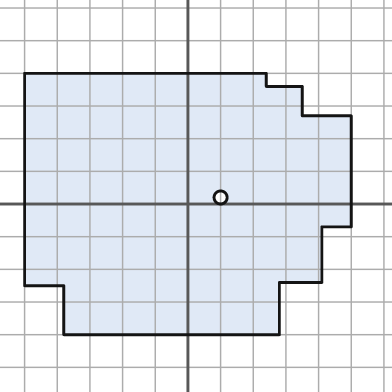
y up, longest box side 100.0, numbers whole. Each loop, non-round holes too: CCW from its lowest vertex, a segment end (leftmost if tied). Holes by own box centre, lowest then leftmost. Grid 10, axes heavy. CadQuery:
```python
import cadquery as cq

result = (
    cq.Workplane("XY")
    .moveTo(-38.0, -40.0)
    .lineTo(28.0, -40.0)
    .lineTo(28.0, -24.0)
    .lineTo(41.0, -24.0)
    .lineTo(41.0, -7.0)
    .lineTo(50.0, -7.0)
    .lineTo(50.0, 27.0)
    .lineTo(35.0, 27.0)
    .lineTo(35.0, 36.0)
    .lineTo(24.0, 36.0)
    .lineTo(24.0, 40.0)
    .lineTo(-50.0, 40.0)
    .lineTo(-50.0, -25.0)
    .lineTo(-38.0, -25.0)
    .close()
    .moveTo(10.0, 2.0)
    .circle(2.0)
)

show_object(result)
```